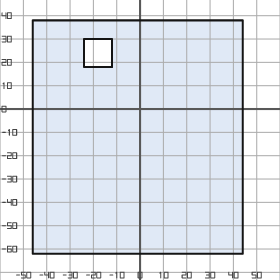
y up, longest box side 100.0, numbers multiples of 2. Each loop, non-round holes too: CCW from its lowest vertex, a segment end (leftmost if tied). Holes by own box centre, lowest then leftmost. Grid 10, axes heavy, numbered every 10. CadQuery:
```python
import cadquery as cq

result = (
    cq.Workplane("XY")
    .moveTo(-46.0, -62.0)
    .lineTo(44.0, -62.0)
    .lineTo(44.0, 38.0)
    .lineTo(-46.0, 38.0)
    .close()
    .moveTo(-24.0, 18.0)
    .lineTo(-12.0, 18.0)
    .lineTo(-12.0, 30.0)
    .lineTo(-24.0, 30.0)
    .close()
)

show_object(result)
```